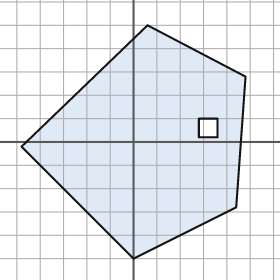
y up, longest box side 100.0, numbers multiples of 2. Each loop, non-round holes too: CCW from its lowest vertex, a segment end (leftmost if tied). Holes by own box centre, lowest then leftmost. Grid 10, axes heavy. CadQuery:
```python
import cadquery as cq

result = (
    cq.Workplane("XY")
    .moveTo(0.0, -50.0)
    .lineTo(44.0, -28.0)
    .lineTo(48.0, 28.0)
    .lineTo(6.0, 50.0)
    .lineTo(-48.0, -2.0)
    .close()
    .moveTo(28.0, 2.0)
    .lineTo(36.0, 2.0)
    .lineTo(36.0, 10.0)
    .lineTo(28.0, 10.0)
    .close()
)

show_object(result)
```